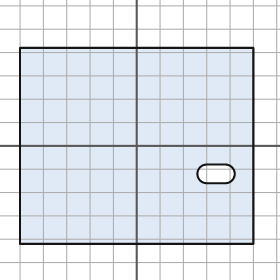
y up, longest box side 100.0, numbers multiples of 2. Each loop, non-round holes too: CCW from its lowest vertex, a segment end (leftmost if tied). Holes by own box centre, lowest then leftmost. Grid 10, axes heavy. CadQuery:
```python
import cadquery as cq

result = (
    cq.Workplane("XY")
    .moveTo(-50.0, -42.0)
    .lineTo(50.0, -42.0)
    .lineTo(50.0, 42.0)
    .lineTo(-50.0, 42.0)
    .close()
    .moveTo(30.0, -16.0)
    .lineTo(38.0, -16.0)
    .threePointArc((42.0, -12.0), (38.0, -8.0))
    .lineTo(30.0, -8.0)
    .threePointArc((26.0, -12.0), (30.0, -16.0))
    .close()
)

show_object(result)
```